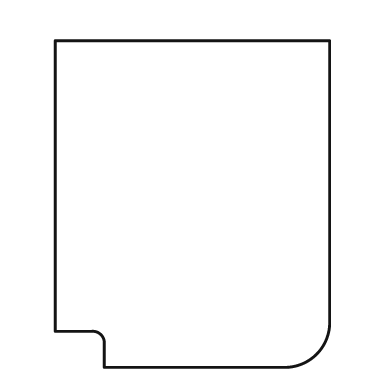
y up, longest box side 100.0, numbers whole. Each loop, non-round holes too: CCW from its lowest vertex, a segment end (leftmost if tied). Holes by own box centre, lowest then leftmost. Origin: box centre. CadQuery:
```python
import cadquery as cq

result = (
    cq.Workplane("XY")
    .moveTo(-27.0, -50.0)
    .lineTo(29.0, -50.0)
    .threePointArc((38.0, -46.0), (42.0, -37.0))
    .lineTo(42.0, 50.0)
    .lineTo(-42.0, 50.0)
    .lineTo(-42.0, -39.0)
    .lineTo(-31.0, -39.0)
    .threePointArc((-28.0, -40.0), (-27.0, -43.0))
    .close()
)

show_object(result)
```